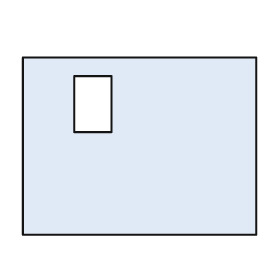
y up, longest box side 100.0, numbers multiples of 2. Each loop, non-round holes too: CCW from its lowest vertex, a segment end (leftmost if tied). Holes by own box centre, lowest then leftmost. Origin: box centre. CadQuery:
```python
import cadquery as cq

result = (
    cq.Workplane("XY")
    .moveTo(-50.0, -38.0)
    .lineTo(50.0, -38.0)
    .lineTo(50.0, 38.0)
    .lineTo(-50.0, 38.0)
    .close()
    .moveTo(-28.0, 6.0)
    .lineTo(-12.0, 6.0)
    .lineTo(-12.0, 30.0)
    .lineTo(-28.0, 30.0)
    .close()
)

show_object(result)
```